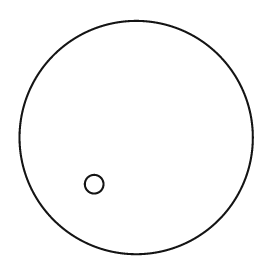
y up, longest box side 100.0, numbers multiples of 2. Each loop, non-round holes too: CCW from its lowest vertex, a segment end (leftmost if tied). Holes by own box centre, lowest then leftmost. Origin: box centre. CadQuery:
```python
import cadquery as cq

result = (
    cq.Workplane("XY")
    .moveTo(0.0, 0.0)
    .circle(50.0)
    .moveTo(-18.0, -20.0)
    .circle(4.0)
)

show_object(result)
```